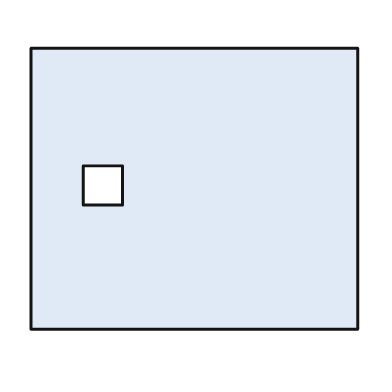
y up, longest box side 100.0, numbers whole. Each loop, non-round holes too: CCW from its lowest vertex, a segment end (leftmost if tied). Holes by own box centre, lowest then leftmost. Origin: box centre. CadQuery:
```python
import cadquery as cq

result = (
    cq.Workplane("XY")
    .moveTo(-50.0, -43.0)
    .lineTo(50.0, -43.0)
    .lineTo(50.0, 43.0)
    .lineTo(-50.0, 43.0)
    .close()
    .moveTo(-34.0, -5.0)
    .lineTo(-22.0, -5.0)
    .lineTo(-22.0, 7.0)
    .lineTo(-34.0, 7.0)
    .close()
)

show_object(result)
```